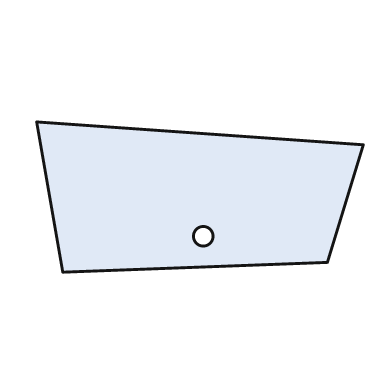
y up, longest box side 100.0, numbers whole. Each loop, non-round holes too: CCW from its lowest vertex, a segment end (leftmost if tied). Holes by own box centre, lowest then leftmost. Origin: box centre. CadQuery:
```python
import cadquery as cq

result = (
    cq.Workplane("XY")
    .moveTo(-42.0, -23.0)
    .lineTo(39.0, -20.0)
    .lineTo(50.0, 16.0)
    .lineTo(-50.0, 23.0)
    .close()
    .moveTo(1.0, -12.0)
    .circle(3.0)
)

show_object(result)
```